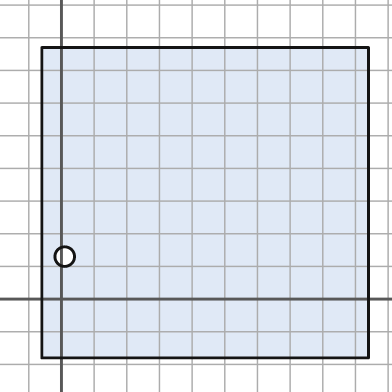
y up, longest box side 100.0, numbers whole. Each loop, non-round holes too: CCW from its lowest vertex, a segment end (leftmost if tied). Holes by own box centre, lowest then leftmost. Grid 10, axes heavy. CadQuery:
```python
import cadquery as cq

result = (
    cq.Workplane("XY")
    .moveTo(-6.0, -18.0)
    .lineTo(94.0, -18.0)
    .lineTo(94.0, 77.0)
    .lineTo(-6.0, 77.0)
    .close()
    .moveTo(1.0, 13.0)
    .circle(3.0)
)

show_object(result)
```